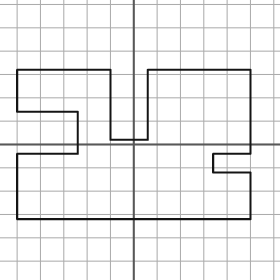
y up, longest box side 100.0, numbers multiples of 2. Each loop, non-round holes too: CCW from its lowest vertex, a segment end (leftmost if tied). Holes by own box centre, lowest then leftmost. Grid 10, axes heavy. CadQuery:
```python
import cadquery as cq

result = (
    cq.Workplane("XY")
    .moveTo(-50.0, -32.0)
    .lineTo(50.0, -32.0)
    .lineTo(50.0, -12.0)
    .lineTo(34.0, -12.0)
    .lineTo(34.0, -4.0)
    .lineTo(50.0, -4.0)
    .lineTo(50.0, 32.0)
    .lineTo(6.0, 32.0)
    .lineTo(6.0, 2.0)
    .lineTo(-10.0, 2.0)
    .lineTo(-10.0, 32.0)
    .lineTo(-50.0, 32.0)
    .lineTo(-50.0, 14.0)
    .lineTo(-24.0, 14.0)
    .lineTo(-24.0, -4.0)
    .lineTo(-50.0, -4.0)
    .close()
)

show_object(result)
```